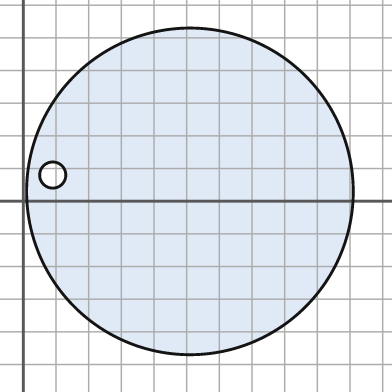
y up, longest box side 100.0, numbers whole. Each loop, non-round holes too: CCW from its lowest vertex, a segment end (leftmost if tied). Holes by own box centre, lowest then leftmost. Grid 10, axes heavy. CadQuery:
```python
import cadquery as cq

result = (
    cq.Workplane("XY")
    .moveTo(51.0, 3.0)
    .circle(50.0)
    .moveTo(9.0, 8.0)
    .circle(4.0)
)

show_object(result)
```